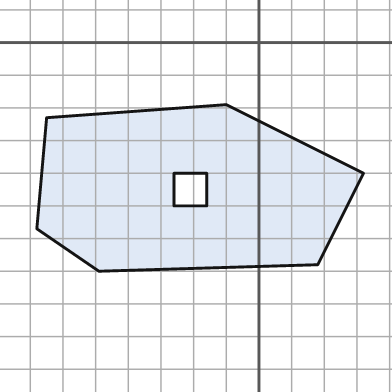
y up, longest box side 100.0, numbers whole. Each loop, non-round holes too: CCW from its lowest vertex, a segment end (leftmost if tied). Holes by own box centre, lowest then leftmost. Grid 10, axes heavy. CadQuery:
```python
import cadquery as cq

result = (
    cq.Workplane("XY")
    .moveTo(-49.0, -70.0)
    .lineTo(18.0, -68.0)
    .lineTo(32.0, -40.0)
    .lineTo(-10.0, -19.0)
    .lineTo(-65.0, -23.0)
    .lineTo(-68.0, -57.0)
    .close()
    .moveTo(-26.0, -50.0)
    .lineTo(-16.0, -50.0)
    .lineTo(-16.0, -40.0)
    .lineTo(-26.0, -40.0)
    .close()
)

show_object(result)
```